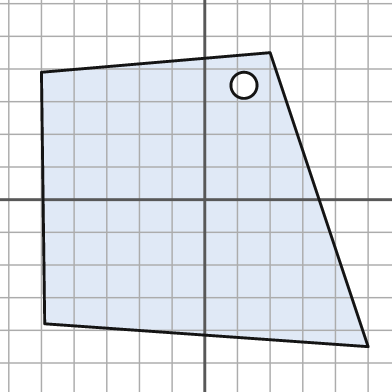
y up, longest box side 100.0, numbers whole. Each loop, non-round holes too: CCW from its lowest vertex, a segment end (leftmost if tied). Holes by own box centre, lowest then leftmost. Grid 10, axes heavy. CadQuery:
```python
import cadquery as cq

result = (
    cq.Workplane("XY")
    .moveTo(50.0, -45.0)
    .lineTo(20.0, 45.0)
    .lineTo(-50.0, 39.0)
    .lineTo(-49.0, -38.0)
    .close()
    .moveTo(12.0, 35.0)
    .circle(4.0)
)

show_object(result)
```